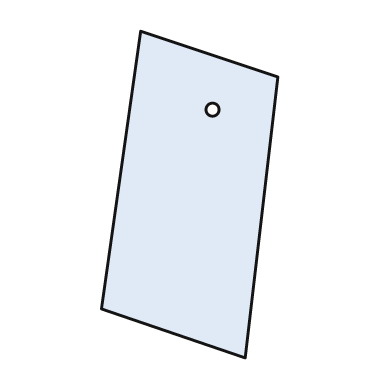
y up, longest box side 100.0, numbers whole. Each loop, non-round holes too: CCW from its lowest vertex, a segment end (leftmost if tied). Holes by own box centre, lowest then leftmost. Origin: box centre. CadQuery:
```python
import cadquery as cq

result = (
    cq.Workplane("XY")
    .moveTo(17.0, -50.0)
    .lineTo(27.0, 36.0)
    .lineTo(-15.0, 50.0)
    .lineTo(-27.0, -35.0)
    .close()
    .moveTo(7.0, 26.0)
    .circle(2.0)
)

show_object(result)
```